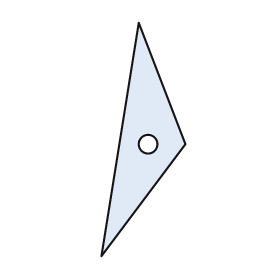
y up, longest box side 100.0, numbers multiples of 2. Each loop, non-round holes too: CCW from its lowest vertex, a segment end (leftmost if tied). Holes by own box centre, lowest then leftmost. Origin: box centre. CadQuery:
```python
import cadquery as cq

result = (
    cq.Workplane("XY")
    .moveTo(-18.0, -50.0)
    .lineTo(18.0, -2.0)
    .lineTo(-2.0, 50.0)
    .close()
    .moveTo(2.0, -2.0)
    .circle(4.0)
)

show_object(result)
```